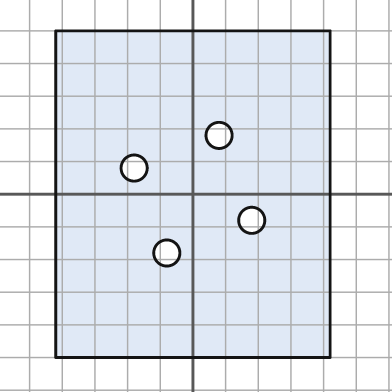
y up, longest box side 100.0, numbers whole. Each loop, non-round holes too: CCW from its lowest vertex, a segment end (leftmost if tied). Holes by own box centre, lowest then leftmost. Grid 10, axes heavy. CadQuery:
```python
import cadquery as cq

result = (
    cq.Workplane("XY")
    .moveTo(-42.0, -50.0)
    .lineTo(42.0, -50.0)
    .lineTo(42.0, 50.0)
    .lineTo(-42.0, 50.0)
    .close()
    .moveTo(-8.0, -18.0)
    .circle(4.0)
    .moveTo(18.0, -8.0)
    .circle(4.0)
    .moveTo(-18.0, 8.0)
    .circle(4.0)
    .moveTo(8.0, 18.0)
    .circle(4.0)
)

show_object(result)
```